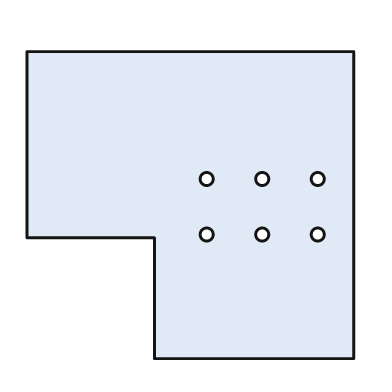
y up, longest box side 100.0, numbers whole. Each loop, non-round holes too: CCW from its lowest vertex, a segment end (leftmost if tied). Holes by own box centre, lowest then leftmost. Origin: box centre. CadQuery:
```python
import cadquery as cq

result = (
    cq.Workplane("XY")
    .moveTo(-11.0, -47.0)
    .lineTo(50.0, -47.0)
    .lineTo(50.0, 47.0)
    .lineTo(-50.0, 47.0)
    .lineTo(-50.0, -10.0)
    .lineTo(-11.0, -10.0)
    .close()
    .moveTo(5.0, -9.0)
    .circle(2.0)
    .moveTo(22.0, -9.0)
    .circle(2.0)
    .moveTo(39.0, -9.0)
    .circle(2.0)
    .moveTo(5.0, 8.0)
    .circle(2.0)
    .moveTo(22.0, 8.0)
    .circle(2.0)
    .moveTo(39.0, 8.0)
    .circle(2.0)
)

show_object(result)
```